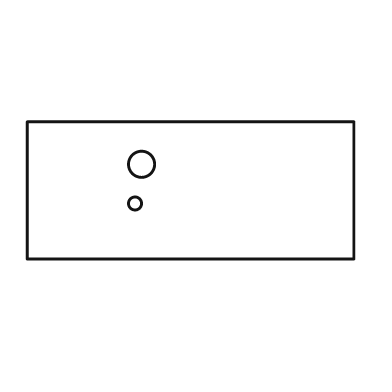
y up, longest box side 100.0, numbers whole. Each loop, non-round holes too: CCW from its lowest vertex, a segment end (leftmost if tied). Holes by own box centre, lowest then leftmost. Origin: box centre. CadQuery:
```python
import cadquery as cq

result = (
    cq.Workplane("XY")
    .moveTo(-50.0, -21.0)
    .lineTo(50.0, -21.0)
    .lineTo(50.0, 21.0)
    .lineTo(-50.0, 21.0)
    .close()
    .moveTo(-17.0, -4.0)
    .circle(2.0)
    .moveTo(-15.0, 8.0)
    .circle(4.0)
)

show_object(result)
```